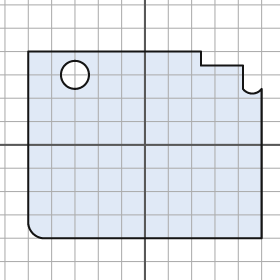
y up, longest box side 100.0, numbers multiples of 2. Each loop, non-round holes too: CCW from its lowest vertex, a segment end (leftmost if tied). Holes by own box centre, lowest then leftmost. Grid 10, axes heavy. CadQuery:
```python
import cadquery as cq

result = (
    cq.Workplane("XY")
    .moveTo(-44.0, -40.0)
    .lineTo(50.0, -40.0)
    .lineTo(50.0, 24.0)
    .threePointArc((46.0, 22.0), (42.0, 24.0))
    .lineTo(42.0, 34.0)
    .lineTo(24.0, 34.0)
    .lineTo(24.0, 40.0)
    .lineTo(-50.0, 40.0)
    .lineTo(-50.0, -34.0)
    .threePointArc((-48.0, -38.0), (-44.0, -40.0))
    .close()
    .moveTo(-30.0, 30.0)
    .circle(6.0)
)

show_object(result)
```